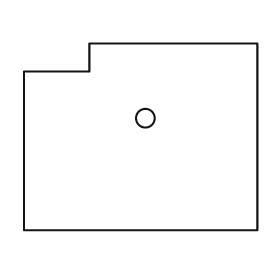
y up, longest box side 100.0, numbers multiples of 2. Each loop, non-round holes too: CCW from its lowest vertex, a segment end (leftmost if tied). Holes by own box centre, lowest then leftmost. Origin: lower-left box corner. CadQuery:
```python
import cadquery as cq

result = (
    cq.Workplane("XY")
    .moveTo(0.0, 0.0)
    .lineTo(100.0, 0.0)
    .lineTo(100.0, 80.0)
    .lineTo(28.0, 80.0)
    .lineTo(28.0, 68.0)
    .lineTo(0.0, 68.0)
    .close()
    .moveTo(52.0, 48.0)
    .circle(4.0)
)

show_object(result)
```